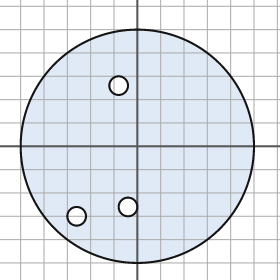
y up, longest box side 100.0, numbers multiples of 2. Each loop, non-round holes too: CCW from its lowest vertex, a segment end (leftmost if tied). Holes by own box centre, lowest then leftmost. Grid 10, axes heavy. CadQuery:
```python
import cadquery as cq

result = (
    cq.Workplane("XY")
    .moveTo(0.0, 0.0)
    .circle(50.0)
    .moveTo(-26.0, -30.0)
    .circle(4.0)
    .moveTo(-4.0, -26.0)
    .circle(4.0)
    .moveTo(-8.0, 26.0)
    .circle(4.0)
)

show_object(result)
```